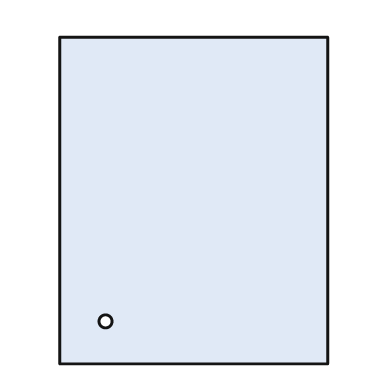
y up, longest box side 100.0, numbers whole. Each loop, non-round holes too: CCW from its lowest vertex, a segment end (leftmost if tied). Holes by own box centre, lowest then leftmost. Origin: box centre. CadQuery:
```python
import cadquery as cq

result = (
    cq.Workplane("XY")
    .moveTo(-41.0, -50.0)
    .lineTo(41.0, -50.0)
    .lineTo(41.0, 50.0)
    .lineTo(-41.0, 50.0)
    .close()
    .moveTo(-27.0, -37.0)
    .circle(2.0)
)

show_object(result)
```